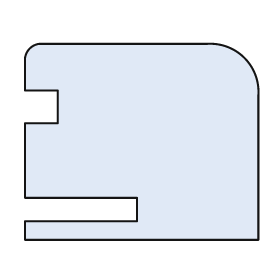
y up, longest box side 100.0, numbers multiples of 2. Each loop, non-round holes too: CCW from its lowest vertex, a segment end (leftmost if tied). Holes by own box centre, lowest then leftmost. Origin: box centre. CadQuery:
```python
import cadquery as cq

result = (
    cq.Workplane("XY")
    .moveTo(-50.0, -42.0)
    .lineTo(50.0, -42.0)
    .lineTo(50.0, 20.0)
    .threePointArc((44.0, 36.0), (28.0, 42.0))
    .lineTo(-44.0, 42.0)
    .threePointArc((-48.0, 40.0), (-50.0, 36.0))
    .lineTo(-50.0, 22.0)
    .lineTo(-36.0, 22.0)
    .lineTo(-36.0, 8.0)
    .lineTo(-50.0, 8.0)
    .lineTo(-50.0, -24.0)
    .lineTo(-2.0, -24.0)
    .lineTo(-2.0, -34.0)
    .lineTo(-50.0, -34.0)
    .close()
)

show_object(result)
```